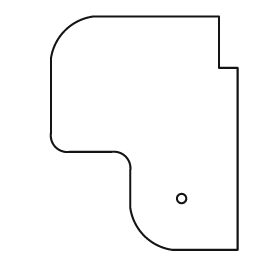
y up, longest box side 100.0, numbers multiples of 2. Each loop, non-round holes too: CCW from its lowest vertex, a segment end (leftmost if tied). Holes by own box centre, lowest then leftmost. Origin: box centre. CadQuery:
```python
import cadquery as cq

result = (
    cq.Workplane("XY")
    .moveTo(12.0, -50.0)
    .lineTo(40.0, -50.0)
    .lineTo(40.0, 28.0)
    .lineTo(32.0, 28.0)
    .lineTo(32.0, 50.0)
    .lineTo(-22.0, 50.0)
    .threePointArc((-34.0, 44.0), (-40.0, 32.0))
    .lineTo(-40.0, 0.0)
    .threePointArc((-38.0, -6.0), (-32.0, -8.0))
    .lineTo(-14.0, -8.0)
    .threePointArc((-8.0, -10.0), (-6.0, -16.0))
    .lineTo(-6.0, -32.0)
    .threePointArc((0.0, -44.0), (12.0, -50.0))
    .close()
    .moveTo(16.0, -28.0)
    .circle(2.0)
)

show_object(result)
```